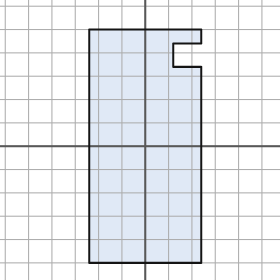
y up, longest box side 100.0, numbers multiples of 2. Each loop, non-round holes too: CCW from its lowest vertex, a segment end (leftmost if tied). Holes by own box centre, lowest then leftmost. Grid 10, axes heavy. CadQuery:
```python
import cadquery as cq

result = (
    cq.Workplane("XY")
    .moveTo(-24.0, -50.0)
    .lineTo(24.0, -50.0)
    .lineTo(24.0, 34.0)
    .lineTo(12.0, 34.0)
    .lineTo(12.0, 44.0)
    .lineTo(24.0, 44.0)
    .lineTo(24.0, 50.0)
    .lineTo(-24.0, 50.0)
    .close()
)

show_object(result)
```